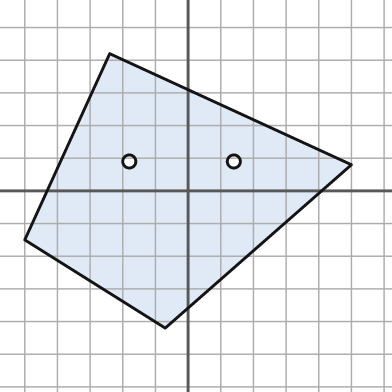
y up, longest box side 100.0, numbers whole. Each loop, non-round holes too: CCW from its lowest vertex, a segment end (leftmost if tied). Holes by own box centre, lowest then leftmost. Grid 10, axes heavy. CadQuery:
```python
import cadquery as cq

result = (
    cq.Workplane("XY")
    .moveTo(-7.0, -42.0)
    .lineTo(50.0, 8.0)
    .lineTo(-24.0, 42.0)
    .lineTo(-50.0, -15.0)
    .close()
    .moveTo(-18.0, 9.0)
    .circle(2.0)
    .moveTo(14.0, 9.0)
    .circle(2.0)
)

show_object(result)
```